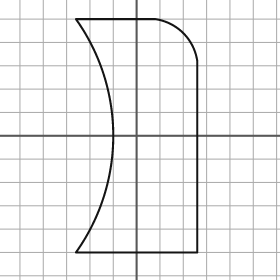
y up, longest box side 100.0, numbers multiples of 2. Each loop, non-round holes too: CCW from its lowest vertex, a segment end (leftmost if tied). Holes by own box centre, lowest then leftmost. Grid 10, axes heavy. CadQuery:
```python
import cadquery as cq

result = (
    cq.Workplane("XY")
    .moveTo(-26.0, -50.0)
    .lineTo(26.0, -50.0)
    .lineTo(26.0, 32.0)
    .threePointArc((20.0, 44.0), (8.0, 50.0))
    .lineTo(-26.0, 50.0)
    .threePointArc((-10.0, 0.0), (-26.0, -50.0))
    .close()
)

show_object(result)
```